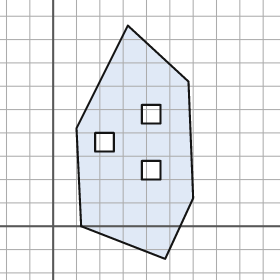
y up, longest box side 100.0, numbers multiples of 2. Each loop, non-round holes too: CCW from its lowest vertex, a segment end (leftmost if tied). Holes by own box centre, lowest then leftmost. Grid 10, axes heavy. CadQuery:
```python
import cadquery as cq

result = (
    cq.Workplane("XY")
    .moveTo(48.0, -14.0)
    .lineTo(60.0, 12.0)
    .lineTo(58.0, 62.0)
    .lineTo(32.0, 86.0)
    .lineTo(10.0, 42.0)
    .lineTo(12.0, 0.0)
    .close()
    .moveTo(38.0, 20.0)
    .lineTo(46.0, 20.0)
    .lineTo(46.0, 28.0)
    .lineTo(38.0, 28.0)
    .close()
    .moveTo(18.0, 32.0)
    .lineTo(26.0, 32.0)
    .lineTo(26.0, 40.0)
    .lineTo(18.0, 40.0)
    .close()
    .moveTo(38.0, 44.0)
    .lineTo(46.0, 44.0)
    .lineTo(46.0, 52.0)
    .lineTo(38.0, 52.0)
    .close()
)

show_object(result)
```